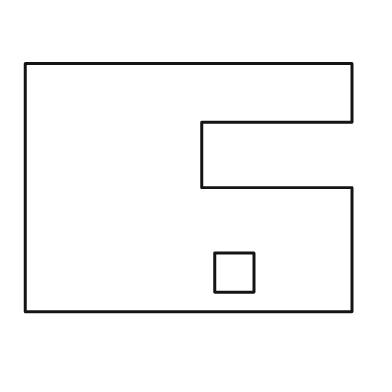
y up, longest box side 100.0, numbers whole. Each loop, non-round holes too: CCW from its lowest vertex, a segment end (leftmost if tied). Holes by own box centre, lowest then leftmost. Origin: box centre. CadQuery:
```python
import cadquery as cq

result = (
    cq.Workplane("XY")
    .moveTo(-50.0, -38.0)
    .lineTo(50.0, -38.0)
    .lineTo(50.0, 0.0)
    .lineTo(4.0, 0.0)
    .lineTo(4.0, 20.0)
    .lineTo(50.0, 20.0)
    .lineTo(50.0, 38.0)
    .lineTo(-50.0, 38.0)
    .close()
    .moveTo(8.0, -32.0)
    .lineTo(20.0, -32.0)
    .lineTo(20.0, -20.0)
    .lineTo(8.0, -20.0)
    .close()
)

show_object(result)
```